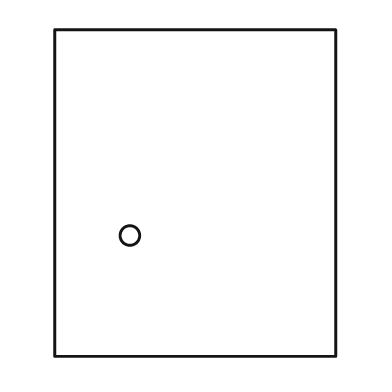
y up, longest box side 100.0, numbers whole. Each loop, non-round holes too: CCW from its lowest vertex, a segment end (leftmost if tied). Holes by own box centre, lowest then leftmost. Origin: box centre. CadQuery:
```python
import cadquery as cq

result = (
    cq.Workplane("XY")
    .moveTo(-43.0, -50.0)
    .lineTo(43.0, -50.0)
    .lineTo(43.0, 50.0)
    .lineTo(-43.0, 50.0)
    .close()
    .moveTo(-20.0, -13.0)
    .circle(3.0)
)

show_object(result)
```